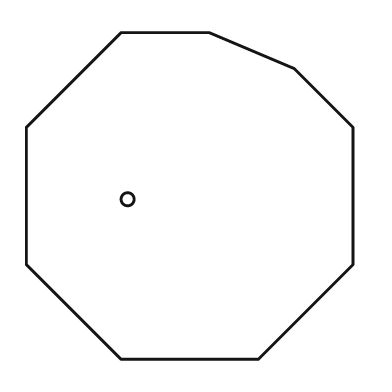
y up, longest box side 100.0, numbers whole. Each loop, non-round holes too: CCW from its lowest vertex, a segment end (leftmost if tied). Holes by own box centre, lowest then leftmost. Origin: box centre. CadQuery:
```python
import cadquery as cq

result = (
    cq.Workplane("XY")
    .moveTo(-21.0, -50.0)
    .lineTo(21.0, -50.0)
    .lineTo(50.0, -21.0)
    .lineTo(50.0, 21.0)
    .lineTo(32.0, 39.0)
    .lineTo(6.0, 50.0)
    .lineTo(-21.0, 50.0)
    .lineTo(-50.0, 21.0)
    .lineTo(-50.0, -21.0)
    .close()
    .moveTo(-19.0, -1.0)
    .circle(2.0)
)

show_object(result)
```